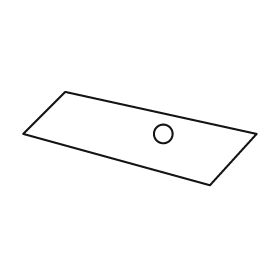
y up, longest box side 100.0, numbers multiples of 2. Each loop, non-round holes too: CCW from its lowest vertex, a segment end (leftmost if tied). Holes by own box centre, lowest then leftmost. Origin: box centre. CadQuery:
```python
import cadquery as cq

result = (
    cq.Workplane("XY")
    .moveTo(30.0, -20.0)
    .lineTo(50.0, 2.0)
    .lineTo(-32.0, 20.0)
    .lineTo(-50.0, 2.0)
    .close()
    .moveTo(10.0, 2.0)
    .circle(4.0)
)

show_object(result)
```